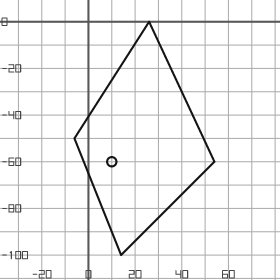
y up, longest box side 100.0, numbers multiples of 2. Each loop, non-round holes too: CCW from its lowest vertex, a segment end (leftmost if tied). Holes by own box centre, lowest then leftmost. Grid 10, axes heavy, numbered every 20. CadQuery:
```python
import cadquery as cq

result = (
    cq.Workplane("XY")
    .moveTo(14.0, -100.0)
    .lineTo(54.0, -60.0)
    .lineTo(26.0, 0.0)
    .lineTo(-6.0, -50.0)
    .close()
    .moveTo(10.0, -60.0)
    .circle(2.0)
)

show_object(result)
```